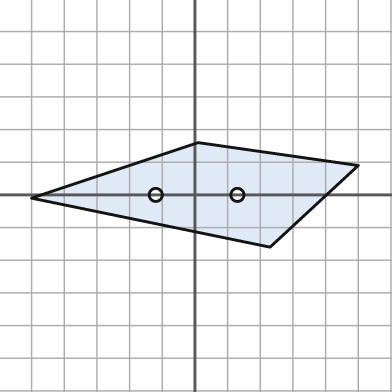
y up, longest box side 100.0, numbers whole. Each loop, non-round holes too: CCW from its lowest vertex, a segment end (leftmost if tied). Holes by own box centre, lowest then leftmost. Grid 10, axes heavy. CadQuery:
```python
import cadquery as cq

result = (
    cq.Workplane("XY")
    .moveTo(23.0, -16.0)
    .lineTo(50.0, 9.0)
    .lineTo(1.0, 16.0)
    .lineTo(-50.0, -1.0)
    .close()
    .moveTo(-12.0, 0.0)
    .circle(2.0)
    .moveTo(13.0, 0.0)
    .circle(2.0)
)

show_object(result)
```